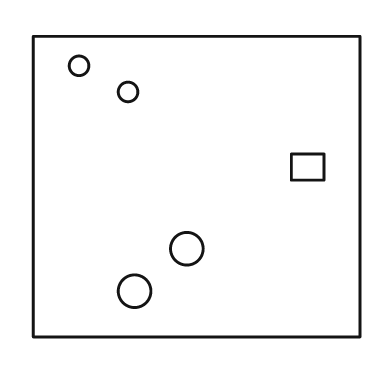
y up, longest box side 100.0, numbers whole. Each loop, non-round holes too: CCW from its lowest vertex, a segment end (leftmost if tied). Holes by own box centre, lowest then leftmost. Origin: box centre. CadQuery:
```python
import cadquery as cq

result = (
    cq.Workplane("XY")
    .moveTo(-50.0, -46.0)
    .lineTo(50.0, -46.0)
    .lineTo(50.0, 46.0)
    .lineTo(-50.0, 46.0)
    .close()
    .moveTo(-19.0, -32.0)
    .circle(5.0)
    .moveTo(-3.0, -19.0)
    .circle(5.0)
    .moveTo(29.0, 2.0)
    .lineTo(39.0, 2.0)
    .lineTo(39.0, 10.0)
    .lineTo(29.0, 10.0)
    .close()
    .moveTo(-21.0, 29.0)
    .circle(3.0)
    .moveTo(-36.0, 37.0)
    .circle(3.0)
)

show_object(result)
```